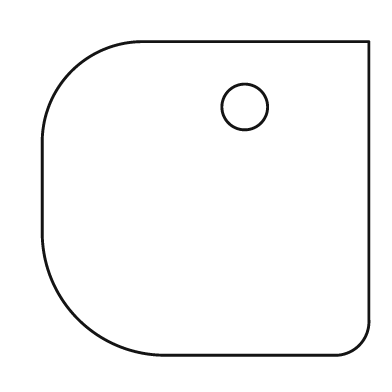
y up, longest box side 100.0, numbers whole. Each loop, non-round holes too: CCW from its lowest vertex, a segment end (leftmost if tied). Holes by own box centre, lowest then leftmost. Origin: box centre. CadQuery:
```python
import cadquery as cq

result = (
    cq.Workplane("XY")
    .moveTo(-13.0, -48.0)
    .lineTo(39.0, -48.0)
    .threePointArc((47.0, -45.0), (50.0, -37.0))
    .lineTo(50.0, 48.0)
    .lineTo(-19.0, 48.0)
    .threePointArc((-41.0, 39.0), (-50.0, 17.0))
    .lineTo(-50.0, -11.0)
    .threePointArc((-39.0, -37.0), (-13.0, -48.0))
    .close()
    .moveTo(12.0, 28.0)
    .circle(7.0)
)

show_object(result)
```